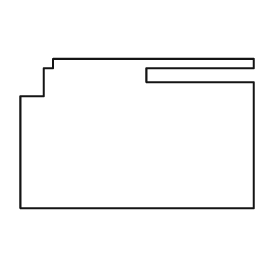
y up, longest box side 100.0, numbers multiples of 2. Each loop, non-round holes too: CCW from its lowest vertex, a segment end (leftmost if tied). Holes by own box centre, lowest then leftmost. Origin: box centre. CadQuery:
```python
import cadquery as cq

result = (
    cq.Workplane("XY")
    .moveTo(-50.0, -32.0)
    .lineTo(50.0, -32.0)
    .lineTo(50.0, 22.0)
    .lineTo(4.0, 22.0)
    .lineTo(4.0, 28.0)
    .lineTo(50.0, 28.0)
    .lineTo(50.0, 32.0)
    .lineTo(-36.0, 32.0)
    .lineTo(-36.0, 28.0)
    .lineTo(-40.0, 28.0)
    .lineTo(-40.0, 16.0)
    .lineTo(-50.0, 16.0)
    .close()
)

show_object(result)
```